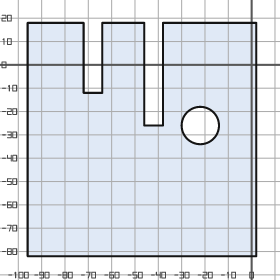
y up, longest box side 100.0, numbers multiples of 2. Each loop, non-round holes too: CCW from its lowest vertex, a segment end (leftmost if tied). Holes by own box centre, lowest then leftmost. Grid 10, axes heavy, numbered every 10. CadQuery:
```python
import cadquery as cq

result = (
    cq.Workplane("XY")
    .moveTo(-96.0, -82.0)
    .lineTo(2.0, -82.0)
    .lineTo(2.0, 18.0)
    .lineTo(-38.0, 18.0)
    .lineTo(-38.0, -26.0)
    .lineTo(-46.0, -26.0)
    .lineTo(-46.0, 18.0)
    .lineTo(-64.0, 18.0)
    .lineTo(-64.0, -12.0)
    .lineTo(-72.0, -12.0)
    .lineTo(-72.0, 18.0)
    .lineTo(-96.0, 18.0)
    .close()
    .moveTo(-22.0, -26.0)
    .circle(8.0)
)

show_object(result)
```